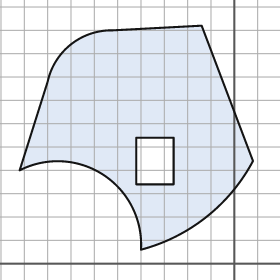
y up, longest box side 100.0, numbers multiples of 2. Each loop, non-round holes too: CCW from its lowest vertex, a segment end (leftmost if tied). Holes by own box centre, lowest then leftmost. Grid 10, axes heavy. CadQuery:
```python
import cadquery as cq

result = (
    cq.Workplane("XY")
    .moveTo(-40.0, 6.0)
    .threePointArc((-12.0, 20.0), (8.0, 44.0))
    .lineTo(-14.0, 102.0)
    .lineTo(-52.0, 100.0)
    .threePointArc((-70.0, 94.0), (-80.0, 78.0))
    .lineTo(-92.0, 40.0)
    .threePointArc((-56.0, 38.0), (-40.0, 6.0))
    .close()
    .moveTo(-42.0, 34.0)
    .lineTo(-26.0, 34.0)
    .lineTo(-26.0, 54.0)
    .lineTo(-42.0, 54.0)
    .close()
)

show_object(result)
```